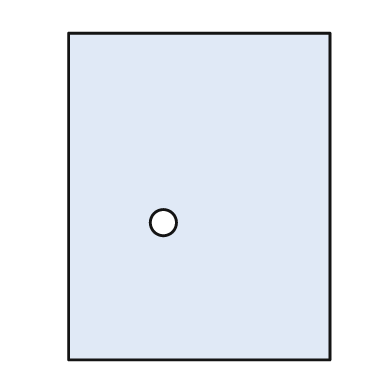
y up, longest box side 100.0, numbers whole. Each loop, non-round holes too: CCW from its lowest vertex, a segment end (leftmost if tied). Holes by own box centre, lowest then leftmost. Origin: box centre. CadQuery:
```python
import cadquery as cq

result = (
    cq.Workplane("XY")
    .moveTo(-40.0, -50.0)
    .lineTo(40.0, -50.0)
    .lineTo(40.0, 50.0)
    .lineTo(-40.0, 50.0)
    .close()
    .moveTo(-11.0, -8.0)
    .circle(4.0)
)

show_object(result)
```